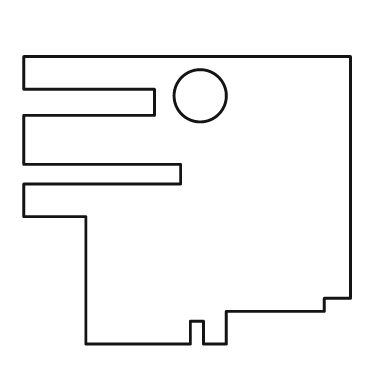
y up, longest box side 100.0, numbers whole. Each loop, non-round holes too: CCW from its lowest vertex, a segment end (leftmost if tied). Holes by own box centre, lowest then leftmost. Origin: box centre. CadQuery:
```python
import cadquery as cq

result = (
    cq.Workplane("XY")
    .moveTo(-31.0, -44.0)
    .lineTo(1.0, -44.0)
    .lineTo(1.0, -37.0)
    .lineTo(5.0, -37.0)
    .lineTo(5.0, -44.0)
    .lineTo(12.0, -44.0)
    .lineTo(12.0, -34.0)
    .lineTo(42.0, -34.0)
    .lineTo(42.0, -30.0)
    .lineTo(50.0, -30.0)
    .lineTo(50.0, 44.0)
    .lineTo(-50.0, 44.0)
    .lineTo(-50.0, 34.0)
    .lineTo(-10.0, 34.0)
    .lineTo(-10.0, 26.0)
    .lineTo(-50.0, 26.0)
    .lineTo(-50.0, 11.0)
    .lineTo(-2.0, 11.0)
    .lineTo(-2.0, 5.0)
    .lineTo(-50.0, 5.0)
    .lineTo(-50.0, -5.0)
    .lineTo(-31.0, -5.0)
    .close()
    .moveTo(4.0, 32.0)
    .circle(8.0)
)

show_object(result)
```